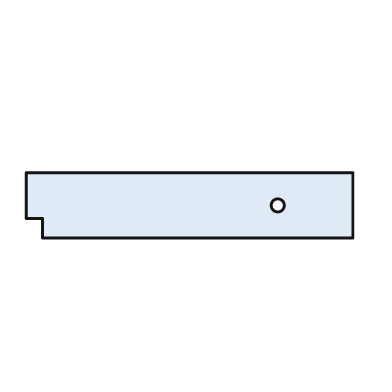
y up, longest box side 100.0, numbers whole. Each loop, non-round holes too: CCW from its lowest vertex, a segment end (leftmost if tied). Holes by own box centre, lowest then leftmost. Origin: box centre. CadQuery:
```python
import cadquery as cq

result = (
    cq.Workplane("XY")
    .moveTo(-45.0, -10.0)
    .lineTo(50.0, -10.0)
    .lineTo(50.0, 10.0)
    .lineTo(-50.0, 10.0)
    .lineTo(-50.0, -4.0)
    .lineTo(-45.0, -4.0)
    .close()
    .moveTo(27.0, 0.0)
    .circle(2.0)
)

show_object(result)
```